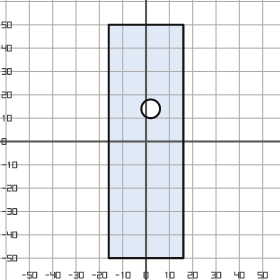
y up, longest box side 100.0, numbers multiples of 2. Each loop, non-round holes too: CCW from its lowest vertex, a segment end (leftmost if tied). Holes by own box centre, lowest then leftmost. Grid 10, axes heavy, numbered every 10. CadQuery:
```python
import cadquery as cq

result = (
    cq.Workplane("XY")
    .moveTo(-16.0, -50.0)
    .lineTo(16.0, -50.0)
    .lineTo(16.0, 50.0)
    .lineTo(-16.0, 50.0)
    .close()
    .moveTo(2.0, 14.0)
    .circle(4.0)
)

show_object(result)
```